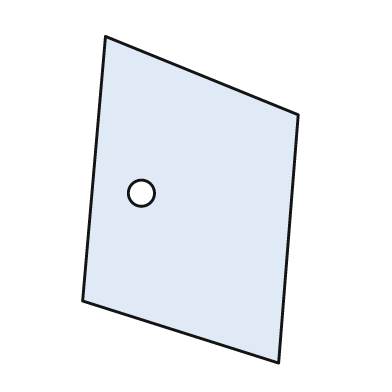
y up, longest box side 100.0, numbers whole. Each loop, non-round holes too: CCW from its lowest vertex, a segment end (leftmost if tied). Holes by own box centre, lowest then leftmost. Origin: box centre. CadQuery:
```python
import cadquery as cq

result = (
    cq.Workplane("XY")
    .moveTo(27.0, -50.0)
    .lineTo(33.0, 26.0)
    .lineTo(-26.0, 50.0)
    .lineTo(-33.0, -31.0)
    .close()
    .moveTo(-15.0, 2.0)
    .circle(4.0)
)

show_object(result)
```